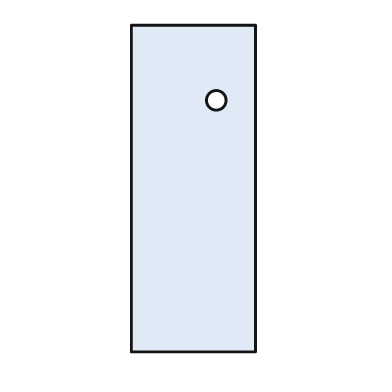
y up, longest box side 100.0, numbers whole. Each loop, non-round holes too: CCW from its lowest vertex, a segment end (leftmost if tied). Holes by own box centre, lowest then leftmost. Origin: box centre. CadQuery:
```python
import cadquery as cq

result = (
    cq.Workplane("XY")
    .moveTo(-19.0, -50.0)
    .lineTo(19.0, -50.0)
    .lineTo(19.0, 50.0)
    .lineTo(-19.0, 50.0)
    .close()
    .moveTo(7.0, 27.0)
    .circle(3.0)
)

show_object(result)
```